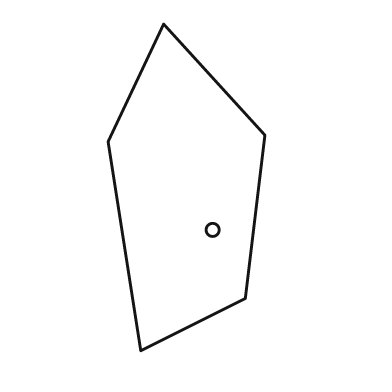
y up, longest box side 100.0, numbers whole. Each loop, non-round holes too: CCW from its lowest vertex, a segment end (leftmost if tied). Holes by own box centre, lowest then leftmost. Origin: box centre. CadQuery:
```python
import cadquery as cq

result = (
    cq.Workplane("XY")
    .moveTo(-14.0, -50.0)
    .lineTo(18.0, -34.0)
    .lineTo(24.0, 16.0)
    .lineTo(-7.0, 50.0)
    .lineTo(-24.0, 14.0)
    .close()
    .moveTo(8.0, -13.0)
    .circle(2.0)
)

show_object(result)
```